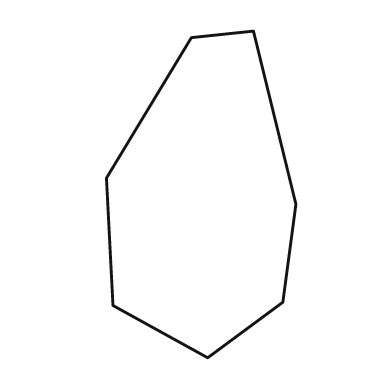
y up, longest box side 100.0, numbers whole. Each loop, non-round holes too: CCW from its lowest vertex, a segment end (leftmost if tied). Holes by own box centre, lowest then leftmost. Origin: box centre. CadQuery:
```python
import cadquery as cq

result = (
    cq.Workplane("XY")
    .moveTo(2.0, -50.0)
    .lineTo(25.0, -33.0)
    .lineTo(29.0, -3.0)
    .lineTo(16.0, 50.0)
    .lineTo(-3.0, 48.0)
    .lineTo(-29.0, 5.0)
    .lineTo(-27.0, -34.0)
    .close()
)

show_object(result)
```